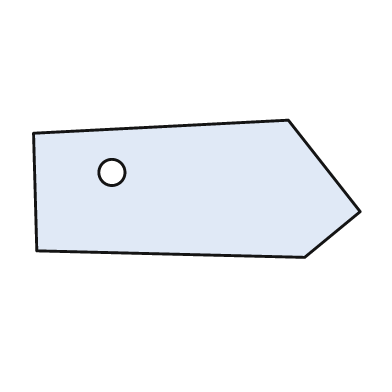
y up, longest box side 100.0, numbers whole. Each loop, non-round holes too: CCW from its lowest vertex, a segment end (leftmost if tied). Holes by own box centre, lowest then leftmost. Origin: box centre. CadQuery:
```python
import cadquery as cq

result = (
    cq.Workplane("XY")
    .moveTo(33.0, -21.0)
    .lineTo(50.0, -7.0)
    .lineTo(28.0, 21.0)
    .lineTo(-50.0, 17.0)
    .lineTo(-49.0, -19.0)
    .close()
    .moveTo(-26.0, 5.0)
    .circle(4.0)
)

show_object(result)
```